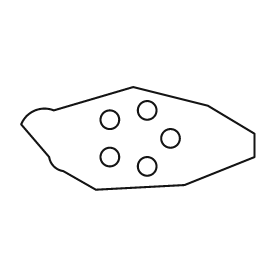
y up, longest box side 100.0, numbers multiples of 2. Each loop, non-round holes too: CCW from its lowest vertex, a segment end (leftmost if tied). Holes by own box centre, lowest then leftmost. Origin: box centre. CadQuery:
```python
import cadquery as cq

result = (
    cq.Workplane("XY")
    .moveTo(-18.0, -22.0)
    .lineTo(20.0, -20.0)
    .lineTo(50.0, -8.0)
    .lineTo(50.0, 2.0)
    .lineTo(30.0, 14.0)
    .lineTo(-2.0, 22.0)
    .lineTo(-36.0, 12.0)
    .threePointArc((-44.0, 12.0), (-50.0, 6.0))
    .lineTo(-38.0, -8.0)
    .threePointArc((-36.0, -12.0), (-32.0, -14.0))
    .close()
    .moveTo(4.0, -12.0)
    .circle(4.0)
    .moveTo(-12.0, -8.0)
    .circle(4.0)
    .moveTo(14.0, 0.0)
    .circle(4.0)
    .moveTo(-12.0, 8.0)
    .circle(4.0)
    .moveTo(4.0, 12.0)
    .circle(4.0)
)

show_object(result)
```